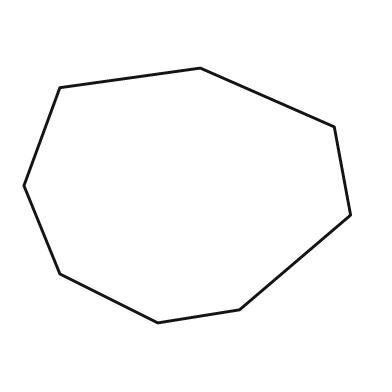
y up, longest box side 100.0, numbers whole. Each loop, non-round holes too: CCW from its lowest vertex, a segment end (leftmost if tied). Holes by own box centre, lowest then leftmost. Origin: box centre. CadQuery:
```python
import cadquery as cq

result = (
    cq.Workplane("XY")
    .moveTo(-9.0, -39.0)
    .lineTo(16.0, -35.0)
    .lineTo(50.0, -6.0)
    .lineTo(45.0, 21.0)
    .lineTo(4.0, 39.0)
    .lineTo(-39.0, 33.0)
    .lineTo(-50.0, 3.0)
    .lineTo(-39.0, -24.0)
    .close()
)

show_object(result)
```